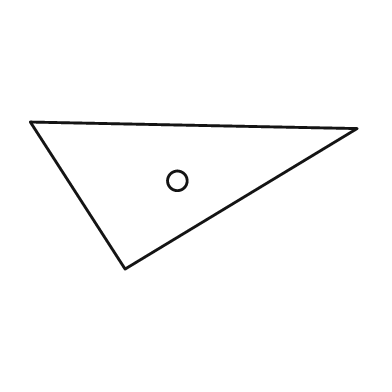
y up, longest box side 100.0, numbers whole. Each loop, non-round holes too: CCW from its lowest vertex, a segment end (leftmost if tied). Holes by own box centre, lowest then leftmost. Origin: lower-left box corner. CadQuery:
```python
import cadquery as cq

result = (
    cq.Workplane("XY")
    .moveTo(29.0, 0.0)
    .lineTo(100.0, 43.0)
    .lineTo(0.0, 45.0)
    .close()
    .moveTo(45.0, 27.0)
    .circle(3.0)
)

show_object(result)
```